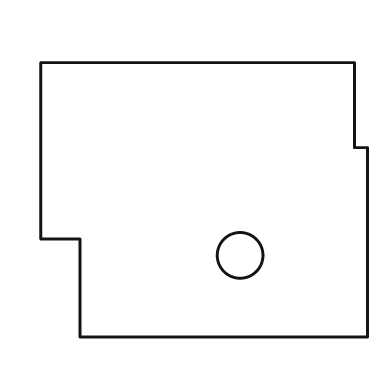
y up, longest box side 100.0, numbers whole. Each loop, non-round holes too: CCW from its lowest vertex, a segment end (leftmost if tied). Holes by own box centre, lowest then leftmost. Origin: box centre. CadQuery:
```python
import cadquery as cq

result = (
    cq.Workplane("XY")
    .moveTo(-38.0, -42.0)
    .lineTo(50.0, -42.0)
    .lineTo(50.0, 16.0)
    .lineTo(46.0, 16.0)
    .lineTo(46.0, 42.0)
    .lineTo(-50.0, 42.0)
    .lineTo(-50.0, -12.0)
    .lineTo(-38.0, -12.0)
    .close()
    .moveTo(11.0, -17.0)
    .circle(7.0)
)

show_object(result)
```